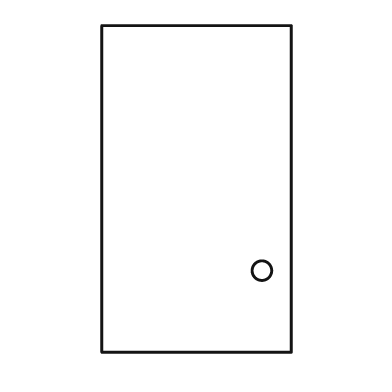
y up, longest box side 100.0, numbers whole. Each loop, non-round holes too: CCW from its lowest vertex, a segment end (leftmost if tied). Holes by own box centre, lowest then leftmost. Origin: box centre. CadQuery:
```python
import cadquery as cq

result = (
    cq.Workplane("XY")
    .moveTo(-29.0, -50.0)
    .lineTo(29.0, -50.0)
    .lineTo(29.0, 50.0)
    .lineTo(-29.0, 50.0)
    .close()
    .moveTo(20.0, -25.0)
    .circle(3.0)
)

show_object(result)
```